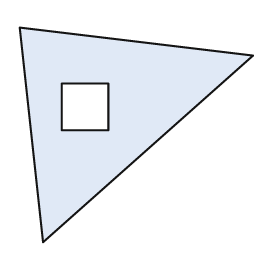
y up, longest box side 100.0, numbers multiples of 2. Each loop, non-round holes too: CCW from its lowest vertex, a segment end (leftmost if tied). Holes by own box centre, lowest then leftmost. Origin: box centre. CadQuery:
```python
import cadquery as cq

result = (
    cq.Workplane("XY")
    .moveTo(-40.0, -46.0)
    .lineTo(50.0, 34.0)
    .lineTo(-50.0, 46.0)
    .close()
    .moveTo(-32.0, 2.0)
    .lineTo(-12.0, 2.0)
    .lineTo(-12.0, 22.0)
    .lineTo(-32.0, 22.0)
    .close()
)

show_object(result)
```